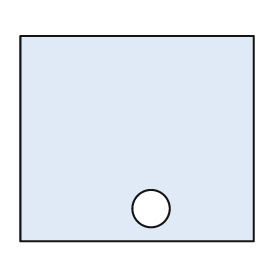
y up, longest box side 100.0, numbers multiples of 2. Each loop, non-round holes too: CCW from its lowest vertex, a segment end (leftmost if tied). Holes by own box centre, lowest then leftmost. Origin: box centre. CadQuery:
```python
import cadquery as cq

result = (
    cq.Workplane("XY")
    .moveTo(-50.0, -44.0)
    .lineTo(50.0, -44.0)
    .lineTo(50.0, 44.0)
    .lineTo(-50.0, 44.0)
    .close()
    .moveTo(6.0, -30.0)
    .circle(8.0)
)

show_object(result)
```